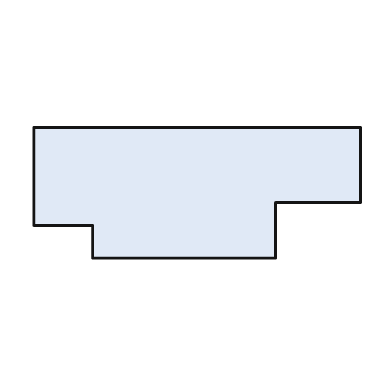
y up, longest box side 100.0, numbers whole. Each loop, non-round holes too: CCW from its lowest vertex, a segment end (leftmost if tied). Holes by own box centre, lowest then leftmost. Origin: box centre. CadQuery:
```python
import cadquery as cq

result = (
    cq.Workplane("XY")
    .moveTo(-32.0, -20.0)
    .lineTo(24.0, -20.0)
    .lineTo(24.0, -3.0)
    .lineTo(50.0, -3.0)
    .lineTo(50.0, 20.0)
    .lineTo(-50.0, 20.0)
    .lineTo(-50.0, -10.0)
    .lineTo(-32.0, -10.0)
    .close()
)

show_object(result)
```